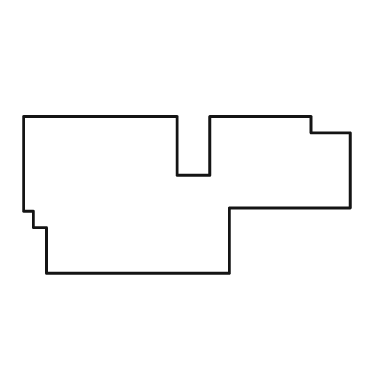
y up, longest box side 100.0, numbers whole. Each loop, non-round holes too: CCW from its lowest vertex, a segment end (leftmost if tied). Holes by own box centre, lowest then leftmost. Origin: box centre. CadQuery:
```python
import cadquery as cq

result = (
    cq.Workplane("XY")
    .moveTo(-43.0, -24.0)
    .lineTo(13.0, -24.0)
    .lineTo(13.0, -4.0)
    .lineTo(50.0, -4.0)
    .lineTo(50.0, 19.0)
    .lineTo(38.0, 19.0)
    .lineTo(38.0, 24.0)
    .lineTo(7.0, 24.0)
    .lineTo(7.0, 6.0)
    .lineTo(-3.0, 6.0)
    .lineTo(-3.0, 24.0)
    .lineTo(-50.0, 24.0)
    .lineTo(-50.0, -5.0)
    .lineTo(-47.0, -5.0)
    .lineTo(-47.0, -10.0)
    .lineTo(-43.0, -10.0)
    .close()
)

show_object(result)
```